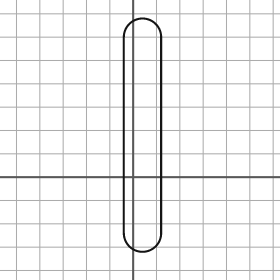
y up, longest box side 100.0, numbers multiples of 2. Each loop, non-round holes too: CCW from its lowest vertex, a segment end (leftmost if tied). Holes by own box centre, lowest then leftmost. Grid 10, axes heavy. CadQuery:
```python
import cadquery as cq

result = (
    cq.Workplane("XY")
    .moveTo(-4.0, -24.0)
    .threePointArc((4.0, -32.0), (12.0, -24.0))
    .lineTo(12.0, 60.0)
    .threePointArc((4.0, 68.0), (-4.0, 60.0))
    .close()
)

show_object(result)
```